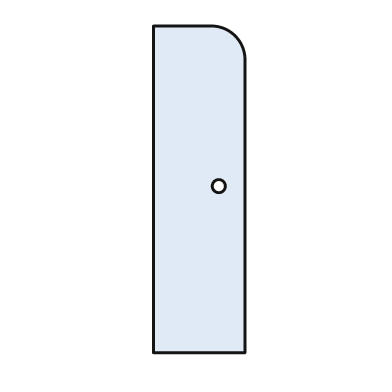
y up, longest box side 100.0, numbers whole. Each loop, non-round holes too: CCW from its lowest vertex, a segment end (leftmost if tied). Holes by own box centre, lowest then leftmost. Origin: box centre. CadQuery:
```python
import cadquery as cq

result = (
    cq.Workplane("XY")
    .moveTo(-14.0, -50.0)
    .lineTo(14.0, -50.0)
    .lineTo(14.0, 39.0)
    .threePointArc((11.0, 47.0), (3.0, 50.0))
    .lineTo(-14.0, 50.0)
    .close()
    .moveTo(6.0, 1.0)
    .circle(2.0)
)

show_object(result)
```